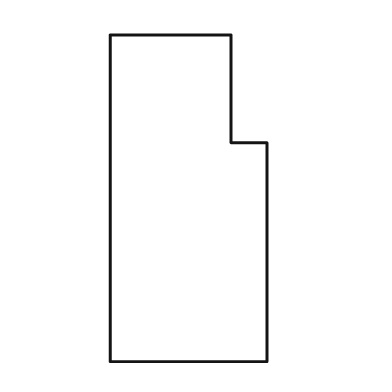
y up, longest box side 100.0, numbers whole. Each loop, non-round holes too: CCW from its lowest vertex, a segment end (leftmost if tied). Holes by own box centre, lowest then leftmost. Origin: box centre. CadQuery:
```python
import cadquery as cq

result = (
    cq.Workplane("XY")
    .moveTo(-24.0, -50.0)
    .lineTo(24.0, -50.0)
    .lineTo(24.0, 17.0)
    .lineTo(13.0, 17.0)
    .lineTo(13.0, 50.0)
    .lineTo(-24.0, 50.0)
    .close()
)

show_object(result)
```